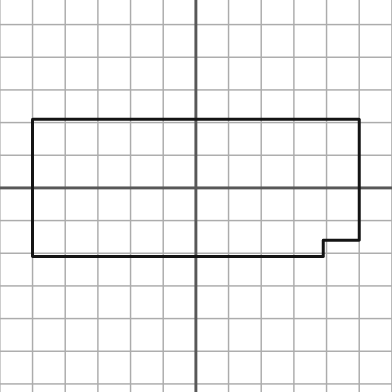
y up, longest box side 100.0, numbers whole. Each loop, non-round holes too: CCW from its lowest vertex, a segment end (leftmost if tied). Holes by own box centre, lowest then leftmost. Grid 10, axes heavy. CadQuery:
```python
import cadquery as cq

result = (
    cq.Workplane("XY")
    .moveTo(-50.0, -21.0)
    .lineTo(39.0, -21.0)
    .lineTo(39.0, -16.0)
    .lineTo(50.0, -16.0)
    .lineTo(50.0, 21.0)
    .lineTo(-50.0, 21.0)
    .close()
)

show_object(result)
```